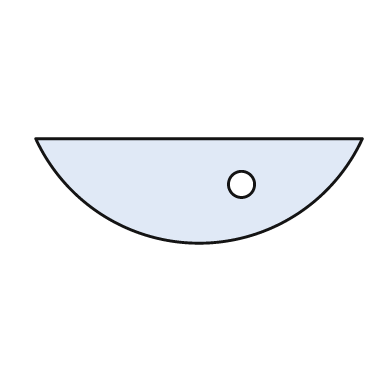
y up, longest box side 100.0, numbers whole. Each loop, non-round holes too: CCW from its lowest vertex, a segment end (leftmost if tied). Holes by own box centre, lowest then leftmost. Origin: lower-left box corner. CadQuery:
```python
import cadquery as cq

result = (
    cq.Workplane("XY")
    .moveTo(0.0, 32.0)
    .threePointArc((50.0, 0.0), (100.0, 32.0))
    .close()
    .moveTo(63.0, 18.0)
    .circle(4.0)
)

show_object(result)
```